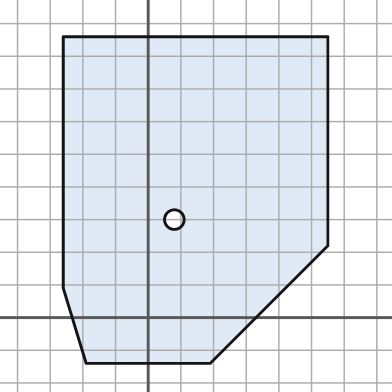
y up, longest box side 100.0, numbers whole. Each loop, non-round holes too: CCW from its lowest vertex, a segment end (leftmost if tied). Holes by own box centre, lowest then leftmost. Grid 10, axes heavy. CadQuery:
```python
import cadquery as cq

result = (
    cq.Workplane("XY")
    .moveTo(-19.0, -14.0)
    .lineTo(19.0, -14.0)
    .lineTo(55.0, 22.0)
    .lineTo(55.0, 86.0)
    .lineTo(-26.0, 86.0)
    .lineTo(-26.0, 9.0)
    .close()
    .moveTo(8.0, 30.0)
    .circle(3.0)
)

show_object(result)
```